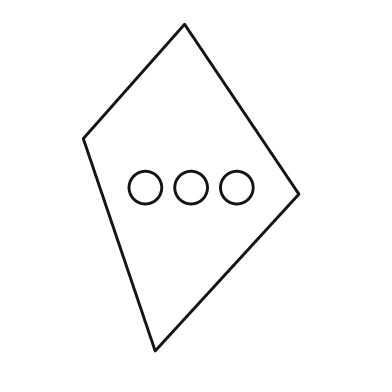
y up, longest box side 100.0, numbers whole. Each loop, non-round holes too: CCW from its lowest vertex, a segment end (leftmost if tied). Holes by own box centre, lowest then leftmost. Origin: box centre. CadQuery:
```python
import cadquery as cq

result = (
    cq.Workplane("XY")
    .moveTo(-11.0, -50.0)
    .lineTo(33.0, -2.0)
    .lineTo(-2.0, 50.0)
    .lineTo(-33.0, 15.0)
    .close()
    .moveTo(-14.0, 0.0)
    .circle(5.0)
    .moveTo(0.0, 0.0)
    .circle(5.0)
    .moveTo(14.0, 0.0)
    .circle(5.0)
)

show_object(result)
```